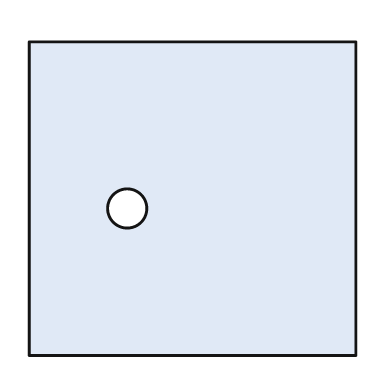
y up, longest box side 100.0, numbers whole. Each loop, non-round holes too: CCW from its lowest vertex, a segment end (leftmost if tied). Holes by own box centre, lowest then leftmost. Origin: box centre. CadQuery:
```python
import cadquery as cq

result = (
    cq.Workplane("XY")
    .moveTo(-50.0, -48.0)
    .lineTo(50.0, -48.0)
    .lineTo(50.0, 48.0)
    .lineTo(-50.0, 48.0)
    .close()
    .moveTo(-20.0, -3.0)
    .circle(6.0)
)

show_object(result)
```